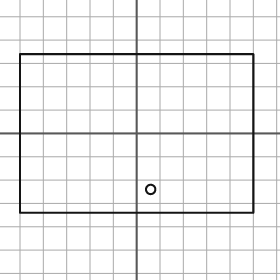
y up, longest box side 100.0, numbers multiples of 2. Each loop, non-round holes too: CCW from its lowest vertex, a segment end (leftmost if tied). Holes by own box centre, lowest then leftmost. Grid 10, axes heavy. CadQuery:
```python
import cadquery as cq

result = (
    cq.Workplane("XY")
    .moveTo(-50.0, -34.0)
    .lineTo(50.0, -34.0)
    .lineTo(50.0, 34.0)
    .lineTo(-50.0, 34.0)
    .close()
    .moveTo(6.0, -24.0)
    .circle(2.0)
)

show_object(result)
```